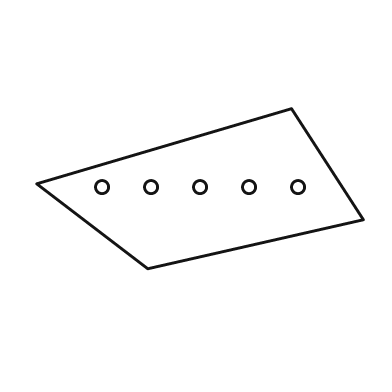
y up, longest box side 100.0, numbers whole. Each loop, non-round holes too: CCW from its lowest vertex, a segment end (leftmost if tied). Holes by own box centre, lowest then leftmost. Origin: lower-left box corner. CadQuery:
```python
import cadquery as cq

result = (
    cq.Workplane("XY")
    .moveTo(34.0, 0.0)
    .lineTo(100.0, 15.0)
    .lineTo(78.0, 49.0)
    .lineTo(0.0, 26.0)
    .close()
    .moveTo(20.0, 25.0)
    .circle(2.0)
    .moveTo(35.0, 25.0)
    .circle(2.0)
    .moveTo(50.0, 25.0)
    .circle(2.0)
    .moveTo(65.0, 25.0)
    .circle(2.0)
    .moveTo(80.0, 25.0)
    .circle(2.0)
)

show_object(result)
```